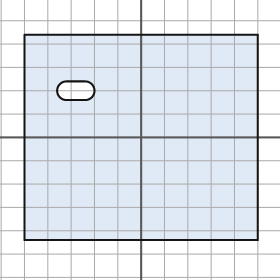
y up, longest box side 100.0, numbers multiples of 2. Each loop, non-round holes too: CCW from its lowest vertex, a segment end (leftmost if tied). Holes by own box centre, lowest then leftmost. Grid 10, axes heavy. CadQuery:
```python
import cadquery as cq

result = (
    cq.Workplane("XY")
    .moveTo(-50.0, -44.0)
    .lineTo(50.0, -44.0)
    .lineTo(50.0, 44.0)
    .lineTo(-50.0, 44.0)
    .close()
    .moveTo(-32.0, 16.0)
    .lineTo(-24.0, 16.0)
    .threePointArc((-20.0, 20.0), (-24.0, 24.0))
    .lineTo(-32.0, 24.0)
    .threePointArc((-36.0, 20.0), (-32.0, 16.0))
    .close()
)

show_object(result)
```